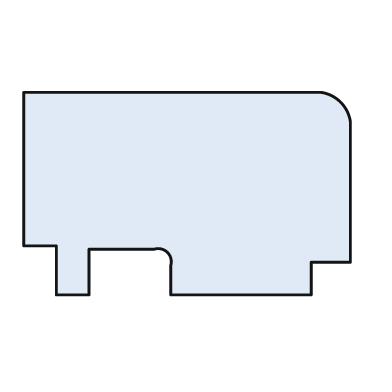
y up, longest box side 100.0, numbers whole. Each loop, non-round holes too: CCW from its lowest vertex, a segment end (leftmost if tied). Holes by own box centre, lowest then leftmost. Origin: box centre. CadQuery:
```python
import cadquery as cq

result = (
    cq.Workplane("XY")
    .moveTo(-40.0, -31.0)
    .lineTo(-30.0, -31.0)
    .lineTo(-30.0, -17.0)
    .lineTo(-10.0, -17.0)
    .threePointArc((-6.0, -18.0), (-5.0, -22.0))
    .lineTo(-5.0, -31.0)
    .lineTo(38.0, -31.0)
    .lineTo(38.0, -21.0)
    .lineTo(50.0, -21.0)
    .lineTo(50.0, 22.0)
    .threePointArc((47.0, 28.0), (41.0, 31.0))
    .lineTo(-50.0, 31.0)
    .lineTo(-50.0, -16.0)
    .lineTo(-40.0, -16.0)
    .close()
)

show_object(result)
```